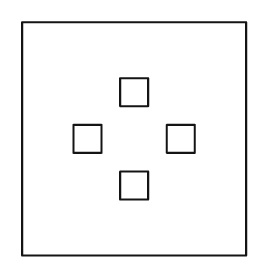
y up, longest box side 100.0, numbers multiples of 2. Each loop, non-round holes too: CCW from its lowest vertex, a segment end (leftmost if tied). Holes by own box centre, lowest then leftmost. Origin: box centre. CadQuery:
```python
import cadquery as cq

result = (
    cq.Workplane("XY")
    .moveTo(-48.0, -50.0)
    .lineTo(48.0, -50.0)
    .lineTo(48.0, 50.0)
    .lineTo(-48.0, 50.0)
    .close()
    .moveTo(-6.0, -26.0)
    .lineTo(6.0, -26.0)
    .lineTo(6.0, -14.0)
    .lineTo(-6.0, -14.0)
    .close()
    .moveTo(-26.0, -6.0)
    .lineTo(-14.0, -6.0)
    .lineTo(-14.0, 6.0)
    .lineTo(-26.0, 6.0)
    .close()
    .moveTo(14.0, -6.0)
    .lineTo(26.0, -6.0)
    .lineTo(26.0, 6.0)
    .lineTo(14.0, 6.0)
    .close()
    .moveTo(-6.0, 14.0)
    .lineTo(6.0, 14.0)
    .lineTo(6.0, 26.0)
    .lineTo(-6.0, 26.0)
    .close()
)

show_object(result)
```